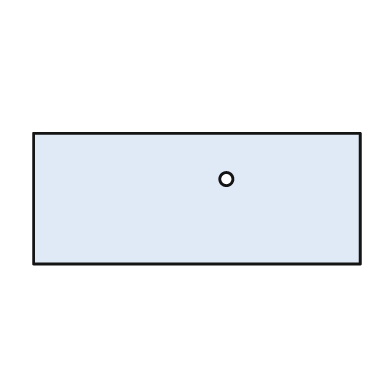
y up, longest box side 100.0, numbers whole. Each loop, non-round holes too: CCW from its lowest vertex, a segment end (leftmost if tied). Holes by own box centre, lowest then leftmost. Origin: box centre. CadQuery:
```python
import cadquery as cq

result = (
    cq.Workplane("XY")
    .moveTo(-50.0, -20.0)
    .lineTo(50.0, -20.0)
    .lineTo(50.0, 20.0)
    .lineTo(-50.0, 20.0)
    .close()
    .moveTo(9.0, 6.0)
    .circle(2.0)
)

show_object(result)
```